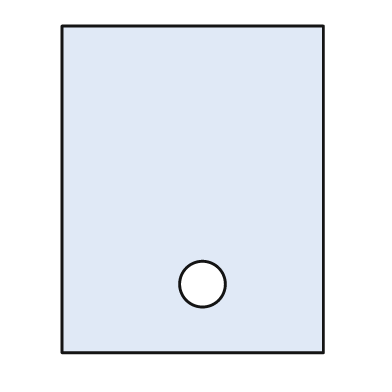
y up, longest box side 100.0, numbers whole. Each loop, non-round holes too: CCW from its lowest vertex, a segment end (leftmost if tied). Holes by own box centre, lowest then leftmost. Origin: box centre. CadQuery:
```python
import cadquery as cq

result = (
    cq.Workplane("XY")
    .moveTo(-40.0, -50.0)
    .lineTo(40.0, -50.0)
    .lineTo(40.0, 50.0)
    .lineTo(-40.0, 50.0)
    .close()
    .moveTo(3.0, -29.0)
    .circle(7.0)
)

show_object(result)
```